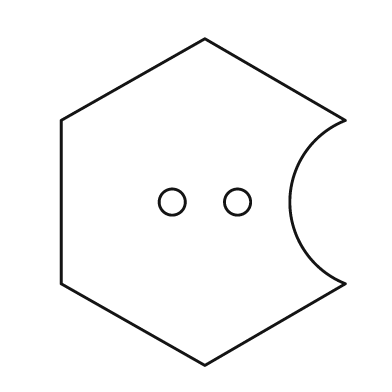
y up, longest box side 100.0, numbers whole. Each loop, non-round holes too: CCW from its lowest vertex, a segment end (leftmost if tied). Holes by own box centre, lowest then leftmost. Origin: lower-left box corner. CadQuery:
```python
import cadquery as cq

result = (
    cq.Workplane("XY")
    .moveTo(44.0, 0.0)
    .lineTo(87.0, 25.0)
    .threePointArc((70.0, 50.0), (87.0, 75.0))
    .lineTo(44.0, 100.0)
    .lineTo(0.0, 75.0)
    .lineTo(0.0, 25.0)
    .close()
    .moveTo(34.0, 50.0)
    .circle(4.0)
    .moveTo(54.0, 50.0)
    .circle(4.0)
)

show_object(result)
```